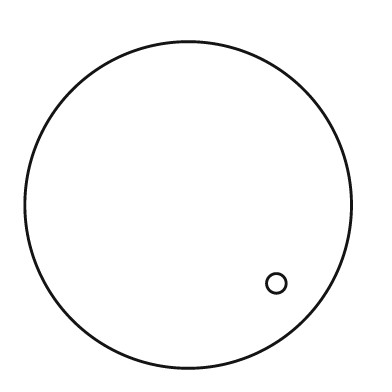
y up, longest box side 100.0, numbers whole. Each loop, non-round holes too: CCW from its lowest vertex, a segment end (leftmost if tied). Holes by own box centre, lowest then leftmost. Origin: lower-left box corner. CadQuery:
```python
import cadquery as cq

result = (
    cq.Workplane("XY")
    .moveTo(50.0, 50.0)
    .circle(50.0)
    .moveTo(77.0, 26.0)
    .circle(3.0)
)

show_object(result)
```